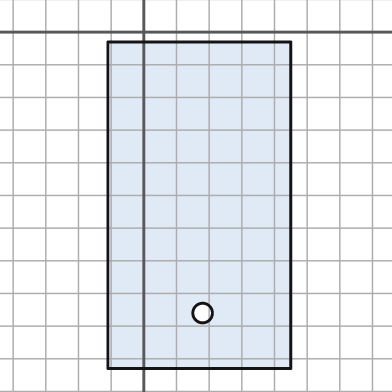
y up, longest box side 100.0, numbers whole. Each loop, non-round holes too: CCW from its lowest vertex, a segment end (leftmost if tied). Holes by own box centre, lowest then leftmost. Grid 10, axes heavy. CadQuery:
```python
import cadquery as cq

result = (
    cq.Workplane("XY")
    .moveTo(-11.0, -103.0)
    .lineTo(45.0, -103.0)
    .lineTo(45.0, -3.0)
    .lineTo(-11.0, -3.0)
    .close()
    .moveTo(18.0, -86.0)
    .circle(3.0)
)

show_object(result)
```